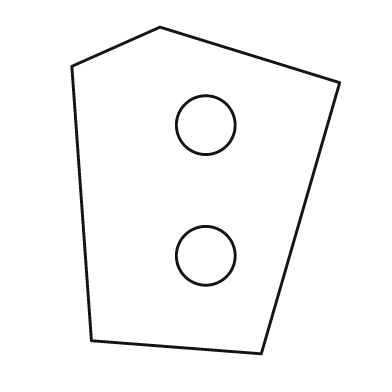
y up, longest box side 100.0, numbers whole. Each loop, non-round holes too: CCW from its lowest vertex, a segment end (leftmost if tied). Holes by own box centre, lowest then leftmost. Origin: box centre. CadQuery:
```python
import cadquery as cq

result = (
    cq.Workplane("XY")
    .moveTo(17.0, -50.0)
    .lineTo(41.0, 33.0)
    .lineTo(-14.0, 50.0)
    .lineTo(-41.0, 38.0)
    .lineTo(-35.0, -46.0)
    .close()
    .moveTo(0.0, -20.0)
    .circle(9.0)
    .moveTo(0.0, 20.0)
    .circle(9.0)
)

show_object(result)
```